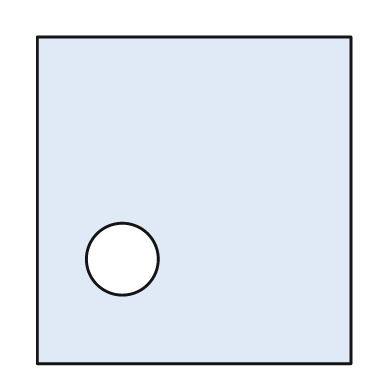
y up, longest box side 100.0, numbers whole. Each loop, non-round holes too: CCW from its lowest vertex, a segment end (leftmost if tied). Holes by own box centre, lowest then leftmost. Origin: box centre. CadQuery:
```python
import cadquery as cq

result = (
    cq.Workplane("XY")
    .moveTo(-48.0, -50.0)
    .lineTo(48.0, -50.0)
    .lineTo(48.0, 50.0)
    .lineTo(-48.0, 50.0)
    .close()
    .moveTo(-22.0, -18.0)
    .circle(11.0)
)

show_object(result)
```